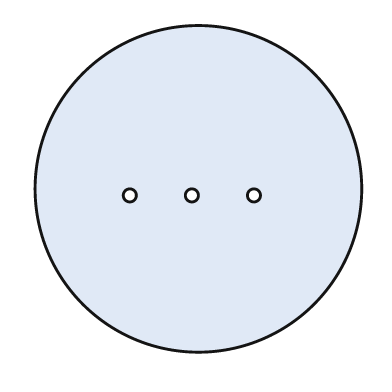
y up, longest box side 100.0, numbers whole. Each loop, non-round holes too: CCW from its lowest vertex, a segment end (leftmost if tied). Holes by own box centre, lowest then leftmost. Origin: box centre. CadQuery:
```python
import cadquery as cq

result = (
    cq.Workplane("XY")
    .moveTo(0.0, 0.0)
    .circle(50.0)
    .moveTo(-21.0, -2.0)
    .circle(2.0)
    .moveTo(-2.0, -2.0)
    .circle(2.0)
    .moveTo(17.0, -2.0)
    .circle(2.0)
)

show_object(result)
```